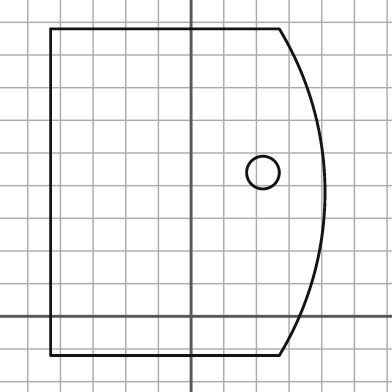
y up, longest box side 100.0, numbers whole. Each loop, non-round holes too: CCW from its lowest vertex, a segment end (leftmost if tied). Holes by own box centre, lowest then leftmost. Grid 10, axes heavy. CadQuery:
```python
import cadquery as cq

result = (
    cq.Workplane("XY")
    .moveTo(-43.0, -12.0)
    .lineTo(27.0, -12.0)
    .threePointArc((41.0, 38.0), (27.0, 88.0))
    .lineTo(-43.0, 88.0)
    .close()
    .moveTo(22.0, 44.0)
    .circle(5.0)
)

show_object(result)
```